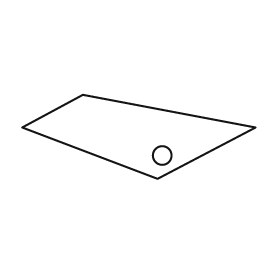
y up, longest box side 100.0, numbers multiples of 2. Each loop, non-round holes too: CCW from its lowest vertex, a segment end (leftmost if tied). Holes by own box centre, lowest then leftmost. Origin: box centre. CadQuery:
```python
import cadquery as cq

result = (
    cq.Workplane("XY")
    .moveTo(8.0, -18.0)
    .lineTo(50.0, 4.0)
    .lineTo(-24.0, 18.0)
    .lineTo(-50.0, 4.0)
    .close()
    .moveTo(10.0, -8.0)
    .circle(4.0)
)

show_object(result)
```